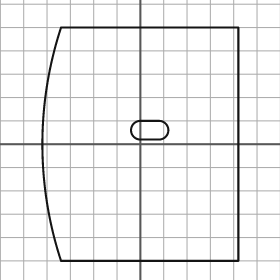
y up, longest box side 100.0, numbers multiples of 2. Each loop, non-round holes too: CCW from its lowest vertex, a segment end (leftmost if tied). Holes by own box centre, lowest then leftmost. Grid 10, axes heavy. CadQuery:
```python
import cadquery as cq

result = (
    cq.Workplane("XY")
    .moveTo(-34.0, -50.0)
    .lineTo(42.0, -50.0)
    .lineTo(42.0, 50.0)
    .lineTo(-34.0, 50.0)
    .threePointArc((-42.0, 0.0), (-34.0, -50.0))
    .close()
    .moveTo(0.0, 2.0)
    .lineTo(8.0, 2.0)
    .threePointArc((12.0, 6.0), (8.0, 10.0))
    .lineTo(0.0, 10.0)
    .threePointArc((-4.0, 6.0), (0.0, 2.0))
    .close()
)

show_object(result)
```